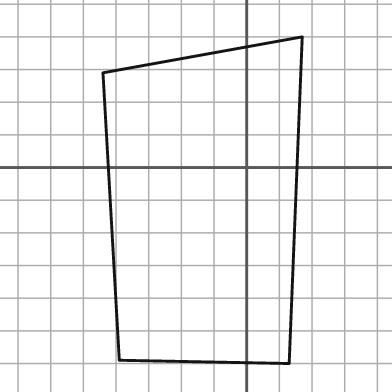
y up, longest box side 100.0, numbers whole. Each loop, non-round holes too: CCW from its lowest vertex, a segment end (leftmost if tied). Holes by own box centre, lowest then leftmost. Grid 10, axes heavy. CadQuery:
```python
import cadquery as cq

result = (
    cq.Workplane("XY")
    .moveTo(13.0, -60.0)
    .lineTo(17.0, 40.0)
    .lineTo(-44.0, 29.0)
    .lineTo(-39.0, -59.0)
    .close()
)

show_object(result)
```